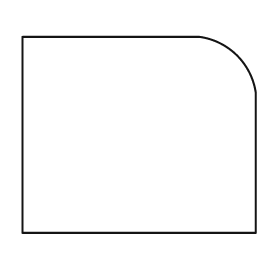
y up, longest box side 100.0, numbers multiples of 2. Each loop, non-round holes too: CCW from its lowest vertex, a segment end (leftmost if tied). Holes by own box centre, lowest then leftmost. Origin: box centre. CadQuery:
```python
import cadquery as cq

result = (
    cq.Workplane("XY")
    .moveTo(-50.0, -42.0)
    .lineTo(50.0, -42.0)
    .lineTo(50.0, 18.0)
    .threePointArc((42.0, 34.0), (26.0, 42.0))
    .lineTo(-50.0, 42.0)
    .close()
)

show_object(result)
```